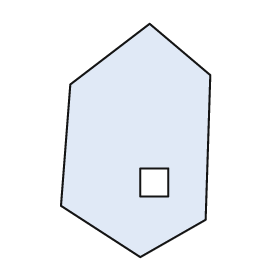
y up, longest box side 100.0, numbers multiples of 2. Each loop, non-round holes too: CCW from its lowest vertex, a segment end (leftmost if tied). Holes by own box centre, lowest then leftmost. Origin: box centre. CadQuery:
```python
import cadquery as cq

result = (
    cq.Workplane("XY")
    .moveTo(2.0, -50.0)
    .lineTo(30.0, -34.0)
    .lineTo(32.0, 28.0)
    .lineTo(6.0, 50.0)
    .lineTo(-28.0, 24.0)
    .lineTo(-32.0, -28.0)
    .close()
    .moveTo(2.0, -24.0)
    .lineTo(14.0, -24.0)
    .lineTo(14.0, -12.0)
    .lineTo(2.0, -12.0)
    .close()
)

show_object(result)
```